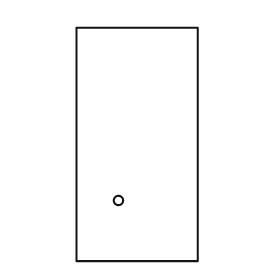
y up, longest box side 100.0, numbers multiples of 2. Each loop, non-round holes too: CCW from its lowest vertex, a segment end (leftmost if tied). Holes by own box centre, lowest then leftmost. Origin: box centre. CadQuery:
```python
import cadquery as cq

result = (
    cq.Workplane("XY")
    .moveTo(-26.0, -50.0)
    .lineTo(26.0, -50.0)
    .lineTo(26.0, 50.0)
    .lineTo(-26.0, 50.0)
    .close()
    .moveTo(-8.0, -24.0)
    .circle(2.0)
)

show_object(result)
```